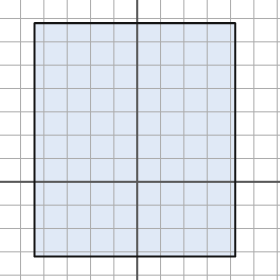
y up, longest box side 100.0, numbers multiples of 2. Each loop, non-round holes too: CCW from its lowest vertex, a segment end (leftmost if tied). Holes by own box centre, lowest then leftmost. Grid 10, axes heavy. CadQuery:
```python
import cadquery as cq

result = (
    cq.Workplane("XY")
    .moveTo(-44.0, -32.0)
    .lineTo(42.0, -32.0)
    .lineTo(42.0, 68.0)
    .lineTo(-44.0, 68.0)
    .close()
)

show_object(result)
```